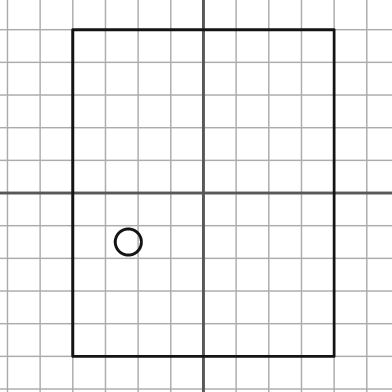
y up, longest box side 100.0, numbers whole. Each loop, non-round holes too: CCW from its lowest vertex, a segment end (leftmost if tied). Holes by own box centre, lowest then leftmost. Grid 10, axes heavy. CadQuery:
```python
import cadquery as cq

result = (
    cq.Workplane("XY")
    .moveTo(-40.0, -50.0)
    .lineTo(40.0, -50.0)
    .lineTo(40.0, 50.0)
    .lineTo(-40.0, 50.0)
    .close()
    .moveTo(-23.0, -15.0)
    .circle(4.0)
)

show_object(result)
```